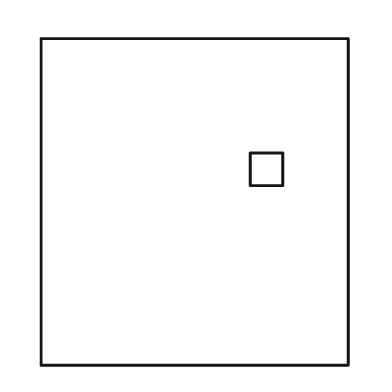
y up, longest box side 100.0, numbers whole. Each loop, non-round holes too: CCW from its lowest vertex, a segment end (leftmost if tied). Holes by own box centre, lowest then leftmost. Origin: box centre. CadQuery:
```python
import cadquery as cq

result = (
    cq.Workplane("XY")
    .moveTo(-47.0, -50.0)
    .lineTo(47.0, -50.0)
    .lineTo(47.0, 50.0)
    .lineTo(-47.0, 50.0)
    .close()
    .moveTo(17.0, 5.0)
    .lineTo(27.0, 5.0)
    .lineTo(27.0, 15.0)
    .lineTo(17.0, 15.0)
    .close()
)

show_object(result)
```